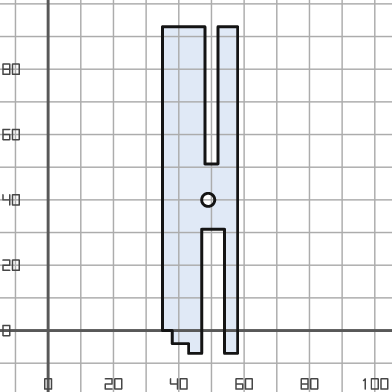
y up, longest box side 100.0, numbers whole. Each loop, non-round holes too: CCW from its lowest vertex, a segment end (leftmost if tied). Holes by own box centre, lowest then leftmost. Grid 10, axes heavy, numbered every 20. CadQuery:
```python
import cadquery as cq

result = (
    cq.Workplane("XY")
    .moveTo(43.0, -7.0)
    .lineTo(47.0, -7.0)
    .lineTo(47.0, 31.0)
    .lineTo(54.0, 31.0)
    .lineTo(54.0, -7.0)
    .lineTo(58.0, -7.0)
    .lineTo(58.0, 93.0)
    .lineTo(52.0, 93.0)
    .lineTo(52.0, 51.0)
    .lineTo(48.0, 51.0)
    .lineTo(48.0, 93.0)
    .lineTo(35.0, 93.0)
    .lineTo(35.0, 0.0)
    .lineTo(38.0, 0.0)
    .lineTo(38.0, -4.0)
    .lineTo(43.0, -4.0)
    .close()
    .moveTo(49.0, 40.0)
    .circle(2.0)
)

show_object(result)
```